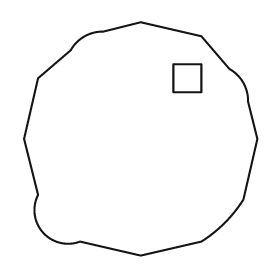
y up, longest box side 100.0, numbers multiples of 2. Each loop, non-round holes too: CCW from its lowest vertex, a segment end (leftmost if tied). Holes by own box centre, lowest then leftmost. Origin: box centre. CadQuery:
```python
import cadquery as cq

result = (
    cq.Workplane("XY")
    .moveTo(0.0, -50.0)
    .lineTo(26.0, -44.0)
    .threePointArc((36.0, -36.0), (44.0, -26.0))
    .lineTo(50.0, 0.0)
    .lineTo(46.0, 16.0)
    .threePointArc((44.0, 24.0), (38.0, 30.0))
    .lineTo(26.0, 44.0)
    .lineTo(0.0, 50.0)
    .lineTo(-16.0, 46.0)
    .threePointArc((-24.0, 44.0), (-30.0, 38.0))
    .lineTo(-44.0, 26.0)
    .lineTo(-50.0, 0.0)
    .lineTo(-44.0, -24.0)
    .threePointArc((-42.0, -40.0), (-26.0, -44.0))
    .close()
    .moveTo(14.0, 20.0)
    .lineTo(26.0, 20.0)
    .lineTo(26.0, 32.0)
    .lineTo(14.0, 32.0)
    .close()
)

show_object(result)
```